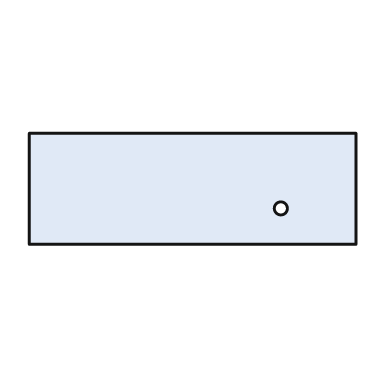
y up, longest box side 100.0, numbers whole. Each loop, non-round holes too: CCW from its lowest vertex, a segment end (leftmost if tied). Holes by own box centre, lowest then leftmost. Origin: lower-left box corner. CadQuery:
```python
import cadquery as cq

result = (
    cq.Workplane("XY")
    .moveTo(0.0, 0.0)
    .lineTo(100.0, 0.0)
    .lineTo(100.0, 34.0)
    .lineTo(0.0, 34.0)
    .close()
    .moveTo(77.0, 11.0)
    .circle(2.0)
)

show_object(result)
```